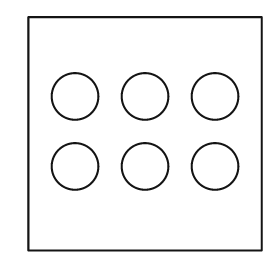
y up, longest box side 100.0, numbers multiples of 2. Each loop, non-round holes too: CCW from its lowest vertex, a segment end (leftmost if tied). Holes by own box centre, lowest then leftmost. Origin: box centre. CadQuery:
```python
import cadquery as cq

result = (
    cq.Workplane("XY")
    .moveTo(-50.0, -50.0)
    .lineTo(50.0, -50.0)
    .lineTo(50.0, 50.0)
    .lineTo(-50.0, 50.0)
    .close()
    .moveTo(-30.0, -14.0)
    .circle(10.0)
    .moveTo(0.0, -14.0)
    .circle(10.0)
    .moveTo(30.0, -14.0)
    .circle(10.0)
    .moveTo(-30.0, 16.0)
    .circle(10.0)
    .moveTo(0.0, 16.0)
    .circle(10.0)
    .moveTo(30.0, 16.0)
    .circle(10.0)
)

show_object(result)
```